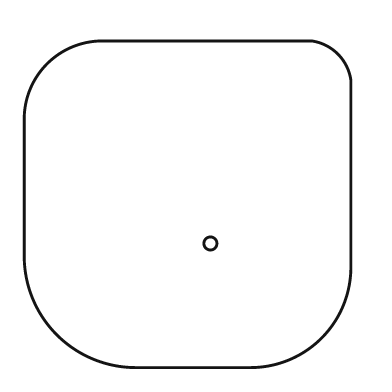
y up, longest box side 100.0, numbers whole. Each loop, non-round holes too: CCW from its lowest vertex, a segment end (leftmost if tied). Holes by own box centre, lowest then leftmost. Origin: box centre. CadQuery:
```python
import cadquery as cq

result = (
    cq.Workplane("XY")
    .moveTo(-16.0, -50.0)
    .lineTo(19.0, -50.0)
    .threePointArc((41.0, -41.0), (50.0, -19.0))
    .lineTo(50.0, 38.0)
    .threePointArc((46.0, 46.0), (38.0, 50.0))
    .lineTo(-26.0, 50.0)
    .threePointArc((-43.0, 43.0), (-50.0, 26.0))
    .lineTo(-50.0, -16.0)
    .threePointArc((-40.0, -40.0), (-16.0, -50.0))
    .close()
    .moveTo(7.0, -12.0)
    .circle(2.0)
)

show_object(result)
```